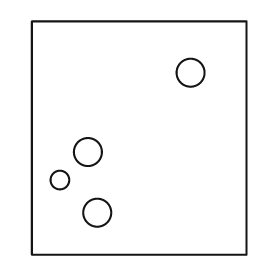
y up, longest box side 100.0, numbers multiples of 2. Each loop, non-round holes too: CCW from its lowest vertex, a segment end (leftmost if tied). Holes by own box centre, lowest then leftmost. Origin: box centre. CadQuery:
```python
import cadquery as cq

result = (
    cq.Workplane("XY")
    .moveTo(-46.0, -50.0)
    .lineTo(46.0, -50.0)
    .lineTo(46.0, 50.0)
    .lineTo(-46.0, 50.0)
    .close()
    .moveTo(-18.0, -32.0)
    .circle(6.0)
    .moveTo(-34.0, -18.0)
    .circle(4.0)
    .moveTo(-22.0, -6.0)
    .circle(6.0)
    .moveTo(22.0, 28.0)
    .circle(6.0)
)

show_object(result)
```